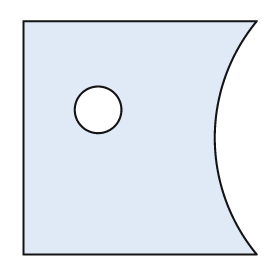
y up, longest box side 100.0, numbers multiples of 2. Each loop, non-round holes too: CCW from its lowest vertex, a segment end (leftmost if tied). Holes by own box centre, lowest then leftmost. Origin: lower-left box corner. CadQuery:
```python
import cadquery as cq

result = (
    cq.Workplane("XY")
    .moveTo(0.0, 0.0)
    .lineTo(100.0, 0.0)
    .threePointArc((82.0, 50.0), (100.0, 100.0))
    .lineTo(0.0, 100.0)
    .close()
    .moveTo(32.0, 62.0)
    .circle(10.0)
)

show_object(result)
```